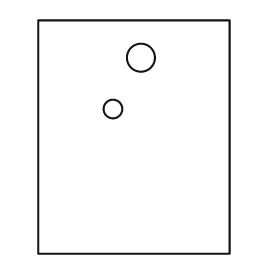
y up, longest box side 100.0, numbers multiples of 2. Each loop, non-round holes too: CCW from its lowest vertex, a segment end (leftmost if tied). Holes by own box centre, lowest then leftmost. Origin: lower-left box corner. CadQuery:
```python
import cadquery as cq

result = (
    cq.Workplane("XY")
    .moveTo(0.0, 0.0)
    .lineTo(82.0, 0.0)
    .lineTo(82.0, 100.0)
    .lineTo(0.0, 100.0)
    .close()
    .moveTo(32.0, 62.0)
    .circle(4.0)
    .moveTo(44.0, 84.0)
    .circle(6.0)
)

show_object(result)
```